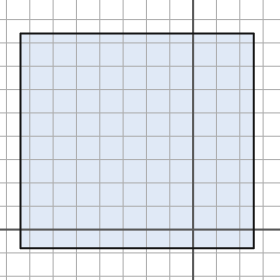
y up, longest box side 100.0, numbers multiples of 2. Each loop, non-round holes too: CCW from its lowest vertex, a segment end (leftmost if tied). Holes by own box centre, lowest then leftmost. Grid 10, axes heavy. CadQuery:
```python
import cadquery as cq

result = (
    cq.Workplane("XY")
    .moveTo(-74.0, -8.0)
    .lineTo(26.0, -8.0)
    .lineTo(26.0, 84.0)
    .lineTo(-74.0, 84.0)
    .close()
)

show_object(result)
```